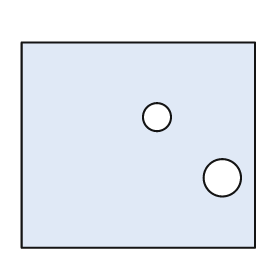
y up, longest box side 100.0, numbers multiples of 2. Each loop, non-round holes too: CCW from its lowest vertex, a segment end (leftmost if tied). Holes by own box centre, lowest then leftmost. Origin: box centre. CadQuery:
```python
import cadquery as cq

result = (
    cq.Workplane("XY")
    .moveTo(-50.0, -44.0)
    .lineTo(50.0, -44.0)
    .lineTo(50.0, 44.0)
    .lineTo(-50.0, 44.0)
    .close()
    .moveTo(36.0, -14.0)
    .circle(8.0)
    .moveTo(8.0, 12.0)
    .circle(6.0)
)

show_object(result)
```